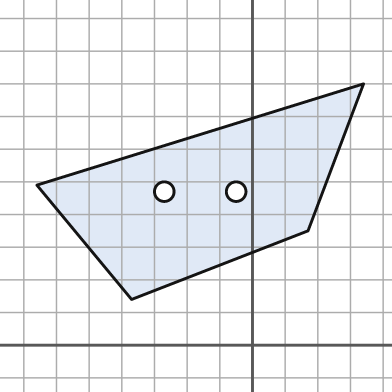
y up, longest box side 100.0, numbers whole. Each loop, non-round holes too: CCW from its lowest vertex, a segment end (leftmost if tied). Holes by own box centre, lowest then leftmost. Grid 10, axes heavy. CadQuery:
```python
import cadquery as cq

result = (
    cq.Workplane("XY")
    .moveTo(-37.0, 14.0)
    .lineTo(17.0, 35.0)
    .lineTo(34.0, 80.0)
    .lineTo(-66.0, 49.0)
    .close()
    .moveTo(-27.0, 47.0)
    .circle(3.0)
    .moveTo(-5.0, 47.0)
    .circle(3.0)
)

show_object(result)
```